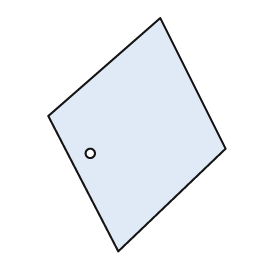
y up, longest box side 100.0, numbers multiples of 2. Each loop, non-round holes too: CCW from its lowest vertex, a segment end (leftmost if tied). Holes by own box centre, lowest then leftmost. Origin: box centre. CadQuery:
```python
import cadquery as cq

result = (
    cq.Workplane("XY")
    .moveTo(-8.0, -50.0)
    .lineTo(38.0, -6.0)
    .lineTo(10.0, 50.0)
    .lineTo(-38.0, 8.0)
    .close()
    .moveTo(-20.0, -8.0)
    .circle(2.0)
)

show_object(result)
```